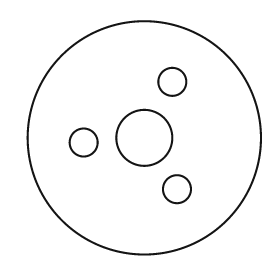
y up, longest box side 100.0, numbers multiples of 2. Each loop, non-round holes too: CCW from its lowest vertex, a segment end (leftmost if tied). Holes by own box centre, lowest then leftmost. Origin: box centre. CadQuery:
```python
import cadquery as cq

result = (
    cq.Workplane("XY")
    .moveTo(0.0, 0.0)
    .circle(50.0)
    .moveTo(14.0, -22.0)
    .circle(6.0)
    .moveTo(-26.0, -2.0)
    .circle(6.0)
    .moveTo(0.0, 0.0)
    .circle(12.0)
    .moveTo(12.0, 24.0)
    .circle(6.0)
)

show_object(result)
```